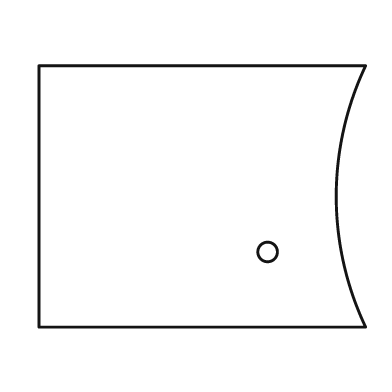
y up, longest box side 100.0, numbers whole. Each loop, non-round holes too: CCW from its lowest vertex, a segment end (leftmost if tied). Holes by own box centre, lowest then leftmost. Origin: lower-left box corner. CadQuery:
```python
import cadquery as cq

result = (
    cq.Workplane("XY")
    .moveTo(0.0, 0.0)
    .lineTo(100.0, 0.0)
    .threePointArc((91.0, 40.0), (100.0, 80.0))
    .lineTo(0.0, 80.0)
    .close()
    .moveTo(70.0, 23.0)
    .circle(3.0)
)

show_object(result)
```